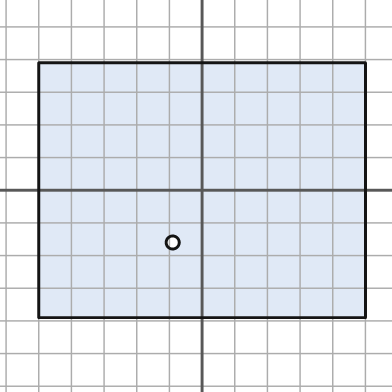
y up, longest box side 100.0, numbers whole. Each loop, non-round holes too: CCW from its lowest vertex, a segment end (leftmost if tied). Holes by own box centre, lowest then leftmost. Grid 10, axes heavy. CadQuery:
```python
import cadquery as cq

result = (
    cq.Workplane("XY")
    .moveTo(-50.0, -39.0)
    .lineTo(50.0, -39.0)
    .lineTo(50.0, 39.0)
    .lineTo(-50.0, 39.0)
    .close()
    .moveTo(-9.0, -16.0)
    .circle(2.0)
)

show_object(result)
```